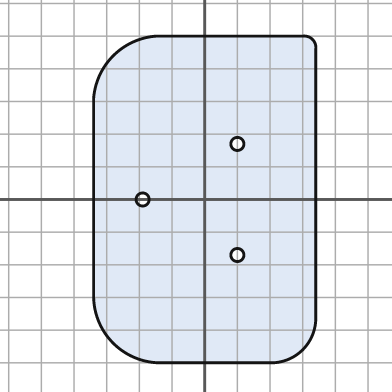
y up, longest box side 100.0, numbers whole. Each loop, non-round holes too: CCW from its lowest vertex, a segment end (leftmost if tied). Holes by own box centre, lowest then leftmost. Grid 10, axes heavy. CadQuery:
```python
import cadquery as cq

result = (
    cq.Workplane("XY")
    .moveTo(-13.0, -50.0)
    .lineTo(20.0, -50.0)
    .threePointArc((30.0, -46.0), (34.0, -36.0))
    .lineTo(34.0, 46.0)
    .threePointArc((33.0, 49.0), (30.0, 50.0))
    .lineTo(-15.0, 50.0)
    .threePointArc((-28.0, 44.0), (-34.0, 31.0))
    .lineTo(-34.0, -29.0)
    .threePointArc((-28.0, -44.0), (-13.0, -50.0))
    .close()
    .moveTo(10.0, -17.0)
    .circle(2.0)
    .moveTo(-19.0, 0.0)
    .circle(2.0)
    .moveTo(10.0, 17.0)
    .circle(2.0)
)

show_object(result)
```